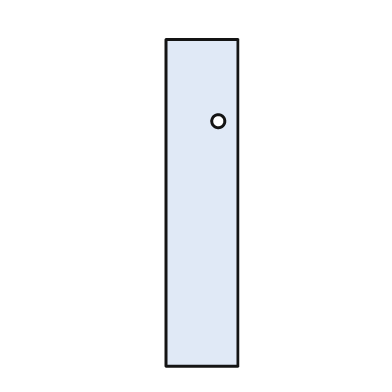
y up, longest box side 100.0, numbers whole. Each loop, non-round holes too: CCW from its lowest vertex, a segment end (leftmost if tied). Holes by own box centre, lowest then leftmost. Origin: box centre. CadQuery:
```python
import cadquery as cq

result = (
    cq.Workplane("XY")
    .moveTo(-11.0, -50.0)
    .lineTo(11.0, -50.0)
    .lineTo(11.0, 50.0)
    .lineTo(-11.0, 50.0)
    .close()
    .moveTo(5.0, 25.0)
    .circle(2.0)
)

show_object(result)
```